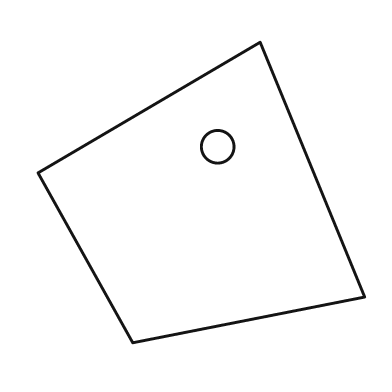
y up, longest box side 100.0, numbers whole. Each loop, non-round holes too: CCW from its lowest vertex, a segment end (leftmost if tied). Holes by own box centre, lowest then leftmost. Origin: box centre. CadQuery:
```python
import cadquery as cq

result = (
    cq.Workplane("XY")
    .moveTo(-21.0, -46.0)
    .lineTo(50.0, -32.0)
    .lineTo(18.0, 46.0)
    .lineTo(-50.0, 6.0)
    .close()
    .moveTo(5.0, 14.0)
    .circle(5.0)
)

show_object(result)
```